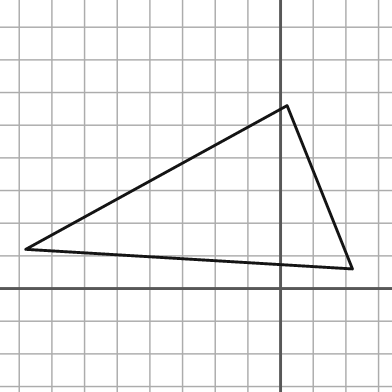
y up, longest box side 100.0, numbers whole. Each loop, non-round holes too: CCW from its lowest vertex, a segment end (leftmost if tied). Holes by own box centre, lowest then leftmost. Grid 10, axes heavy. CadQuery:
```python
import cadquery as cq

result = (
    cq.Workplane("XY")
    .moveTo(22.0, 6.0)
    .lineTo(2.0, 56.0)
    .lineTo(-78.0, 12.0)
    .close()
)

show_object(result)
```